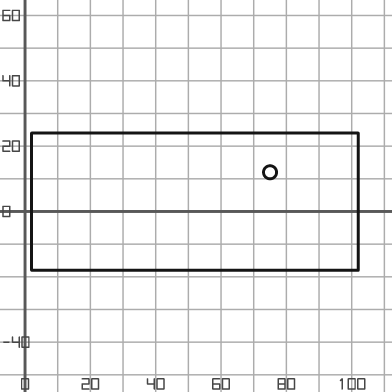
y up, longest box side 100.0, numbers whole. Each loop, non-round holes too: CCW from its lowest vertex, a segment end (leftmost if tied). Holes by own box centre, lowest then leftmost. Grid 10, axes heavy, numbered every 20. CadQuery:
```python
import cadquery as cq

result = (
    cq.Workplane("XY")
    .moveTo(2.0, -18.0)
    .lineTo(102.0, -18.0)
    .lineTo(102.0, 24.0)
    .lineTo(2.0, 24.0)
    .close()
    .moveTo(75.0, 12.0)
    .circle(2.0)
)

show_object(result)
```